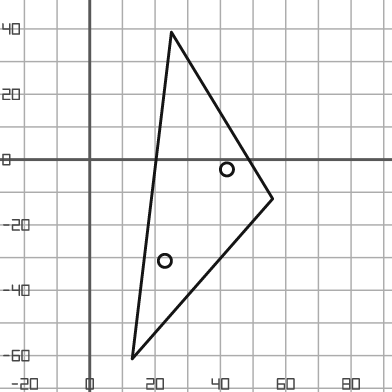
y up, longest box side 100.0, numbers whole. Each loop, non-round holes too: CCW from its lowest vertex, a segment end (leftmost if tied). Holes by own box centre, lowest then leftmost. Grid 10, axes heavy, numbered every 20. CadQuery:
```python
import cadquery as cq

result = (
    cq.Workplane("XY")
    .moveTo(13.0, -61.0)
    .lineTo(56.0, -12.0)
    .lineTo(25.0, 39.0)
    .close()
    .moveTo(23.0, -31.0)
    .circle(2.0)
    .moveTo(42.0, -3.0)
    .circle(2.0)
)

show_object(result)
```